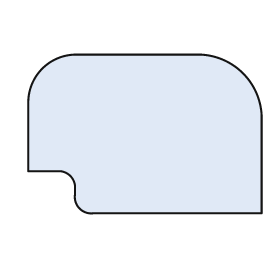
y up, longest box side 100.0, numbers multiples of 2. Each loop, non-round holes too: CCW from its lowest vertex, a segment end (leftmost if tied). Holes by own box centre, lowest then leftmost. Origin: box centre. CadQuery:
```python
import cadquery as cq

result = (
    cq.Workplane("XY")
    .moveTo(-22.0, -34.0)
    .lineTo(50.0, -34.0)
    .lineTo(50.0, 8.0)
    .threePointArc((42.0, 26.0), (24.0, 34.0))
    .lineTo(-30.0, 34.0)
    .threePointArc((-44.0, 28.0), (-50.0, 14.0))
    .lineTo(-50.0, -16.0)
    .lineTo(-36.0, -16.0)
    .threePointArc((-32.0, -18.0), (-30.0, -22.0))
    .lineTo(-30.0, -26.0)
    .threePointArc((-28.0, -32.0), (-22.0, -34.0))
    .close()
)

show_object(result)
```